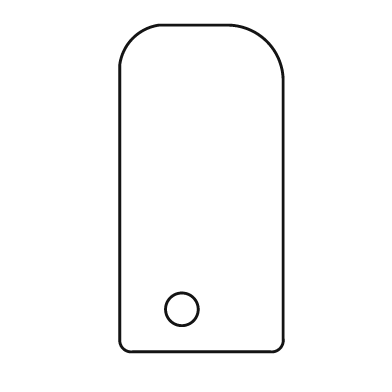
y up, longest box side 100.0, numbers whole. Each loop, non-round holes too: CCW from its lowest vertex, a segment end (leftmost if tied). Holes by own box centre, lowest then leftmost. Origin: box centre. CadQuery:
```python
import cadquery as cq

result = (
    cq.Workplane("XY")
    .moveTo(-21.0, -50.0)
    .lineTo(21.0, -50.0)
    .threePointArc((24.0, -49.0), (25.0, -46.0))
    .lineTo(25.0, 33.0)
    .threePointArc((20.0, 45.0), (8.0, 50.0))
    .lineTo(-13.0, 50.0)
    .threePointArc((-21.0, 46.0), (-25.0, 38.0))
    .lineTo(-25.0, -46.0)
    .threePointArc((-24.0, -49.0), (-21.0, -50.0))
    .close()
    .moveTo(-6.0, -37.0)
    .circle(5.0)
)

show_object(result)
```